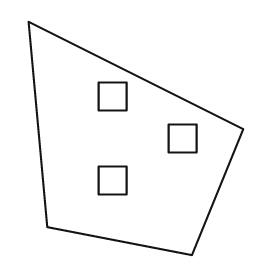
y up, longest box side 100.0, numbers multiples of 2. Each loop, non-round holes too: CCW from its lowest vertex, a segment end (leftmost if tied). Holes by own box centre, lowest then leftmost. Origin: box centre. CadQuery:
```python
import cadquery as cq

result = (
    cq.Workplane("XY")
    .moveTo(24.0, -50.0)
    .lineTo(46.0, 4.0)
    .lineTo(-46.0, 50.0)
    .lineTo(-38.0, -38.0)
    .close()
    .moveTo(-16.0, -24.0)
    .lineTo(-4.0, -24.0)
    .lineTo(-4.0, -12.0)
    .lineTo(-16.0, -12.0)
    .close()
    .moveTo(14.0, -6.0)
    .lineTo(26.0, -6.0)
    .lineTo(26.0, 6.0)
    .lineTo(14.0, 6.0)
    .close()
    .moveTo(-16.0, 12.0)
    .lineTo(-4.0, 12.0)
    .lineTo(-4.0, 24.0)
    .lineTo(-16.0, 24.0)
    .close()
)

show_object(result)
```